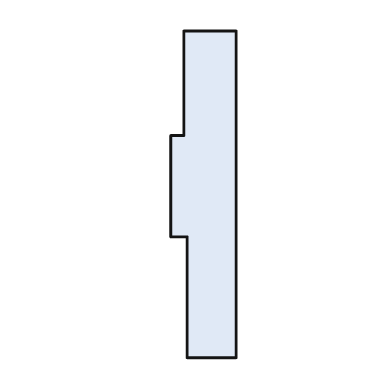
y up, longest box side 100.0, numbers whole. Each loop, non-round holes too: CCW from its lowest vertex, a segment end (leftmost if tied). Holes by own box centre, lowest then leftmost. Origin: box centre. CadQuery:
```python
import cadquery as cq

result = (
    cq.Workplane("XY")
    .moveTo(-5.0, -50.0)
    .lineTo(10.0, -50.0)
    .lineTo(10.0, 50.0)
    .lineTo(-6.0, 50.0)
    .lineTo(-6.0, 18.0)
    .lineTo(-10.0, 18.0)
    .lineTo(-10.0, -13.0)
    .lineTo(-5.0, -13.0)
    .close()
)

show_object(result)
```